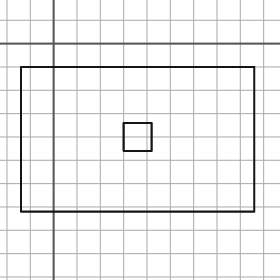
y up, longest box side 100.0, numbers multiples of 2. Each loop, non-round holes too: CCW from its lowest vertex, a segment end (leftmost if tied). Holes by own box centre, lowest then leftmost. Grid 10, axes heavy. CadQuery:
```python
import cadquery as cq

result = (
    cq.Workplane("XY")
    .moveTo(-14.0, -72.0)
    .lineTo(86.0, -72.0)
    .lineTo(86.0, -10.0)
    .lineTo(-14.0, -10.0)
    .close()
    .moveTo(30.0, -46.0)
    .lineTo(42.0, -46.0)
    .lineTo(42.0, -34.0)
    .lineTo(30.0, -34.0)
    .close()
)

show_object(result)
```